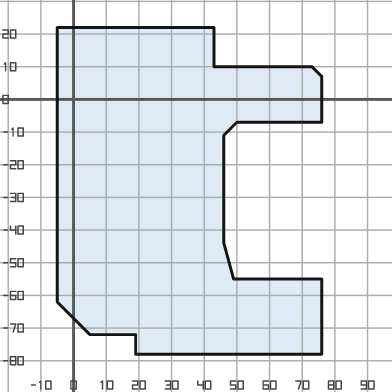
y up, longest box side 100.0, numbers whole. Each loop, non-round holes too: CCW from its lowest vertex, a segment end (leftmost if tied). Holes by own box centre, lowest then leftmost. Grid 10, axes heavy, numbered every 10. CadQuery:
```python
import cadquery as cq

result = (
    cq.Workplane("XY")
    .moveTo(19.0, -78.0)
    .lineTo(76.0, -78.0)
    .lineTo(76.0, -55.0)
    .lineTo(49.0, -55.0)
    .lineTo(46.0, -44.0)
    .lineTo(46.0, -11.0)
    .lineTo(50.0, -7.0)
    .lineTo(76.0, -7.0)
    .lineTo(76.0, 7.0)
    .lineTo(73.0, 10.0)
    .lineTo(43.0, 10.0)
    .lineTo(43.0, 22.0)
    .lineTo(-5.0, 22.0)
    .lineTo(-5.0, -62.0)
    .lineTo(5.0, -72.0)
    .lineTo(19.0, -72.0)
    .close()
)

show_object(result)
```